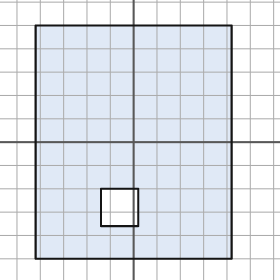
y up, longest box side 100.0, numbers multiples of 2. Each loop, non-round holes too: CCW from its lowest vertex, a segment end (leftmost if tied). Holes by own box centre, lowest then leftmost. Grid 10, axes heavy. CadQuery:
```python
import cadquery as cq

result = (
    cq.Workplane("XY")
    .moveTo(-42.0, -50.0)
    .lineTo(42.0, -50.0)
    .lineTo(42.0, 50.0)
    .lineTo(-42.0, 50.0)
    .close()
    .moveTo(-14.0, -36.0)
    .lineTo(2.0, -36.0)
    .lineTo(2.0, -20.0)
    .lineTo(-14.0, -20.0)
    .close()
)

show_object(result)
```